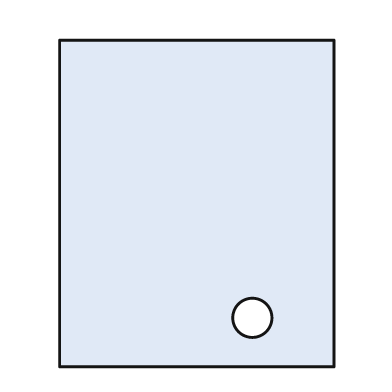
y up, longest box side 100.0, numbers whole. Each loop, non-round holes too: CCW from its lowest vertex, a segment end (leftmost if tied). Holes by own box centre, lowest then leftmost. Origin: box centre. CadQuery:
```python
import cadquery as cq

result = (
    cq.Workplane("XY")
    .moveTo(-42.0, -50.0)
    .lineTo(42.0, -50.0)
    .lineTo(42.0, 50.0)
    .lineTo(-42.0, 50.0)
    .close()
    .moveTo(17.0, -35.0)
    .circle(6.0)
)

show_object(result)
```